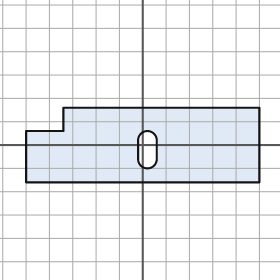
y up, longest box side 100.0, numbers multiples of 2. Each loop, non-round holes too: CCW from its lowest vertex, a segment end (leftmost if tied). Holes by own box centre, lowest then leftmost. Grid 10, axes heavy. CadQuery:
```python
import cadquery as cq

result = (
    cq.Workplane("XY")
    .moveTo(-50.0, -16.0)
    .lineTo(50.0, -16.0)
    .lineTo(50.0, 16.0)
    .lineTo(-34.0, 16.0)
    .lineTo(-34.0, 6.0)
    .lineTo(-50.0, 6.0)
    .close()
    .moveTo(-2.0, -6.0)
    .threePointArc((2.0, -10.0), (6.0, -6.0))
    .lineTo(6.0, 2.0)
    .threePointArc((2.0, 6.0), (-2.0, 2.0))
    .close()
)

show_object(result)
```